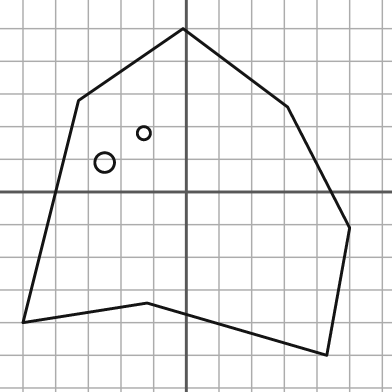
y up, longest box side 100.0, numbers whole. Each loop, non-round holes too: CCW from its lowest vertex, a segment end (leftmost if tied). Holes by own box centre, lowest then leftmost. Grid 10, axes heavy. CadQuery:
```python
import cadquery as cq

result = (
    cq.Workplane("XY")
    .moveTo(43.0, -50.0)
    .lineTo(50.0, -11.0)
    .lineTo(31.0, 26.0)
    .lineTo(-1.0, 50.0)
    .lineTo(-33.0, 28.0)
    .lineTo(-50.0, -40.0)
    .lineTo(-12.0, -34.0)
    .close()
    .moveTo(-25.0, 9.0)
    .circle(3.0)
    .moveTo(-13.0, 18.0)
    .circle(2.0)
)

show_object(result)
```